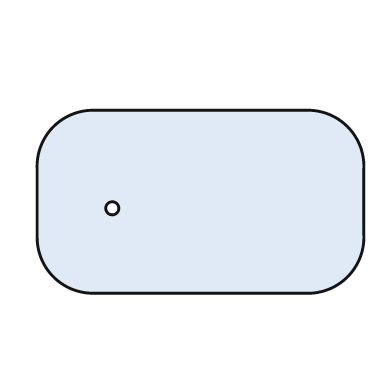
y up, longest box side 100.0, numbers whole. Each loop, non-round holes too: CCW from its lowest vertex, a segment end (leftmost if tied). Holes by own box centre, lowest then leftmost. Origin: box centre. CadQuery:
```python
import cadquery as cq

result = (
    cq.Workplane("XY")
    .moveTo(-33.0, -28.0)
    .lineTo(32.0, -28.0)
    .threePointArc((45.0, -23.0), (50.0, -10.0))
    .lineTo(50.0, 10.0)
    .threePointArc((45.0, 23.0), (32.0, 28.0))
    .lineTo(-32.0, 28.0)
    .threePointArc((-45.0, 23.0), (-50.0, 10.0))
    .lineTo(-50.0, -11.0)
    .threePointArc((-45.0, -23.0), (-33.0, -28.0))
    .close()
    .moveTo(-27.0, -2.0)
    .circle(2.0)
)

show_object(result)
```